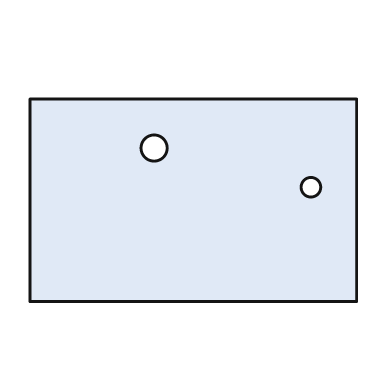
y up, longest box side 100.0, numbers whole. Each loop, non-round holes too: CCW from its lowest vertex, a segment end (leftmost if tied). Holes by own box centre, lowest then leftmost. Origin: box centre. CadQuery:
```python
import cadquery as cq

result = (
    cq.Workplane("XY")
    .moveTo(-50.0, -31.0)
    .lineTo(50.0, -31.0)
    .lineTo(50.0, 31.0)
    .lineTo(-50.0, 31.0)
    .close()
    .moveTo(36.0, 4.0)
    .circle(3.0)
    .moveTo(-12.0, 16.0)
    .circle(4.0)
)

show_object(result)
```